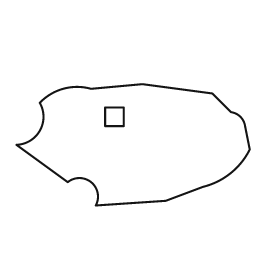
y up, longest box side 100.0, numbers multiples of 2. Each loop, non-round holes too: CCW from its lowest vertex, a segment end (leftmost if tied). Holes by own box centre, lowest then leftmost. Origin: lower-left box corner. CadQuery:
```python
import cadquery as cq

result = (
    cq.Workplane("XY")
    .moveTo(34.0, 0.0)
    .lineTo(64.0, 2.0)
    .lineTo(80.0, 8.0)
    .threePointArc((92.0, 14.0), (100.0, 24.0))
    .lineTo(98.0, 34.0)
    .threePointArc((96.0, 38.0), (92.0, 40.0))
    .lineTo(84.0, 48.0)
    .lineTo(54.0, 52.0)
    .lineTo(32.0, 50.0)
    .threePointArc((20.0, 50.0), (10.0, 44.0))
    .threePointArc((10.0, 32.0), (0.0, 26.0))
    .lineTo(22.0, 10.0)
    .threePointArc((32.0, 10.0), (34.0, 0.0))
    .close()
    .moveTo(38.0, 34.0)
    .lineTo(46.0, 34.0)
    .lineTo(46.0, 42.0)
    .lineTo(38.0, 42.0)
    .close()
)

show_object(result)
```